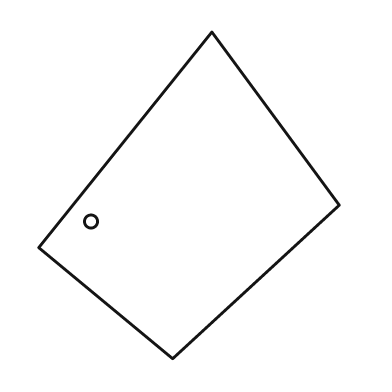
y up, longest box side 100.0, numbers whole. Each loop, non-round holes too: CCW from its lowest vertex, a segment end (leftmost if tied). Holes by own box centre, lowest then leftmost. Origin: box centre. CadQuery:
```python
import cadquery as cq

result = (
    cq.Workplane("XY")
    .moveTo(-5.0, -50.0)
    .lineTo(46.0, -3.0)
    .lineTo(7.0, 50.0)
    .lineTo(-46.0, -16.0)
    .close()
    .moveTo(-30.0, -8.0)
    .circle(2.0)
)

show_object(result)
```